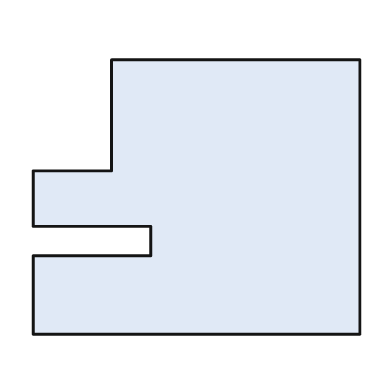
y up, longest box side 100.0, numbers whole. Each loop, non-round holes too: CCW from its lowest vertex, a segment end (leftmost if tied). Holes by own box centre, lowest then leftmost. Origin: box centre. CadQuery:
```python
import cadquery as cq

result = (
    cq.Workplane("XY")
    .moveTo(-50.0, -42.0)
    .lineTo(50.0, -42.0)
    .lineTo(50.0, 42.0)
    .lineTo(-26.0, 42.0)
    .lineTo(-26.0, 8.0)
    .lineTo(-50.0, 8.0)
    .lineTo(-50.0, -9.0)
    .lineTo(-14.0, -9.0)
    .lineTo(-14.0, -18.0)
    .lineTo(-50.0, -18.0)
    .close()
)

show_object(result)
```